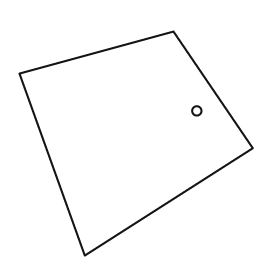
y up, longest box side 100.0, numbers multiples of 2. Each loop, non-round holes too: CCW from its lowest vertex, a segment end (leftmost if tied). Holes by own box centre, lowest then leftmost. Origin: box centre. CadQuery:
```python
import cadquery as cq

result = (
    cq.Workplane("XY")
    .moveTo(-22.0, -48.0)
    .lineTo(50.0, -2.0)
    .lineTo(16.0, 48.0)
    .lineTo(-50.0, 30.0)
    .close()
    .moveTo(26.0, 14.0)
    .circle(2.0)
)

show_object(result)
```